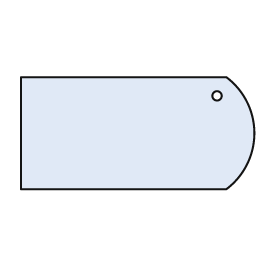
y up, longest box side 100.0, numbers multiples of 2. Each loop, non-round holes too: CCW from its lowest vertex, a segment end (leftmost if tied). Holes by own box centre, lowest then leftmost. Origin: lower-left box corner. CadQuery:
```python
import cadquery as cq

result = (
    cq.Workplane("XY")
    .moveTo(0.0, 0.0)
    .lineTo(88.0, 0.0)
    .threePointArc((100.0, 24.0), (88.0, 48.0))
    .lineTo(0.0, 48.0)
    .close()
    .moveTo(84.0, 40.0)
    .circle(2.0)
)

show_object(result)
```